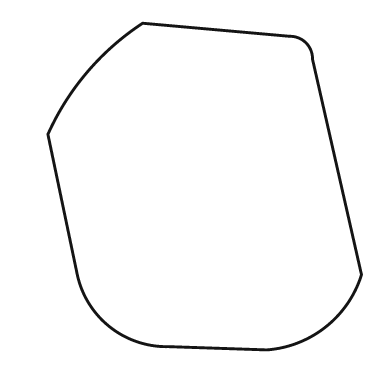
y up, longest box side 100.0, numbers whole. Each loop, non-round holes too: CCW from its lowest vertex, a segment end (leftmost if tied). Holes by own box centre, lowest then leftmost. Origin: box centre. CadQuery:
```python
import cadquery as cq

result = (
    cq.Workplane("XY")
    .moveTo(19.0, -50.0)
    .threePointArc((37.0, -43.0), (48.0, -27.0))
    .lineTo(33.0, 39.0)
    .threePointArc((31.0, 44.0), (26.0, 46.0))
    .lineTo(-19.0, 50.0)
    .threePointArc((-36.0, 35.0), (-48.0, 16.0))
    .lineTo(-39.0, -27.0)
    .threePointArc((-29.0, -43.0), (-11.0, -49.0))
    .close()
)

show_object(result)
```